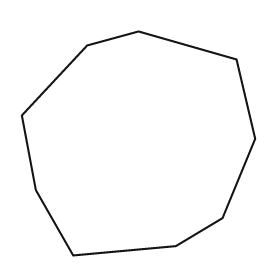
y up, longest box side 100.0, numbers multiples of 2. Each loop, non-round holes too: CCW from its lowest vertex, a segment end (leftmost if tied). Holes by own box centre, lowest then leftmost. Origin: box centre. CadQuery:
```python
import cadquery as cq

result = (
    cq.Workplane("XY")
    .moveTo(-28.0, -48.0)
    .lineTo(16.0, -44.0)
    .lineTo(36.0, -32.0)
    .lineTo(50.0, 2.0)
    .lineTo(42.0, 36.0)
    .lineTo(0.0, 48.0)
    .lineTo(-22.0, 42.0)
    .lineTo(-50.0, 12.0)
    .lineTo(-44.0, -20.0)
    .close()
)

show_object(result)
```